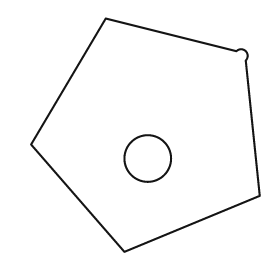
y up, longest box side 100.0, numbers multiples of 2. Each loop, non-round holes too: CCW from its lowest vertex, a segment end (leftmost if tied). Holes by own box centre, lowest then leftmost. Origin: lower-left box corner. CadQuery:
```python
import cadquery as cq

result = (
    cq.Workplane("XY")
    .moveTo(40.0, 0.0)
    .lineTo(98.0, 24.0)
    .lineTo(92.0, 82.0)
    .threePointArc((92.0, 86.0), (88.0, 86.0))
    .lineTo(32.0, 100.0)
    .lineTo(0.0, 46.0)
    .close()
    .moveTo(50.0, 40.0)
    .circle(10.0)
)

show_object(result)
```